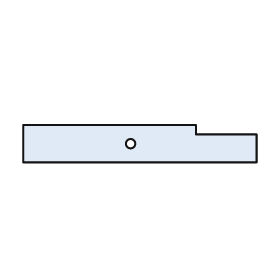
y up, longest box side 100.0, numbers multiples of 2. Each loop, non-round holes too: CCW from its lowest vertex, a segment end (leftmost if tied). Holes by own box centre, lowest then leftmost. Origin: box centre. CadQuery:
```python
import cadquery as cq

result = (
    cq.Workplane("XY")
    .moveTo(-50.0, -8.0)
    .lineTo(50.0, -8.0)
    .lineTo(50.0, 4.0)
    .lineTo(24.0, 4.0)
    .lineTo(24.0, 8.0)
    .lineTo(-50.0, 8.0)
    .close()
    .moveTo(-4.0, 0.0)
    .circle(2.0)
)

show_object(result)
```